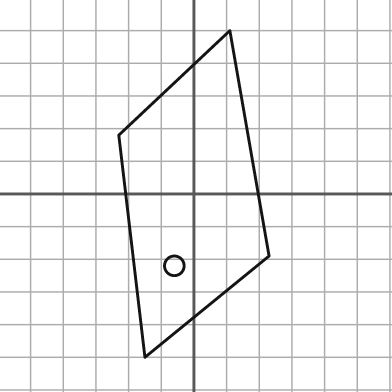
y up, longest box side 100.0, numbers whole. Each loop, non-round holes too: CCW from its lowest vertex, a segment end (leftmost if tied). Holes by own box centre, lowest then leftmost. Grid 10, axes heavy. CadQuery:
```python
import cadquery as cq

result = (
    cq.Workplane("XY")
    .moveTo(-15.0, -50.0)
    .lineTo(23.0, -19.0)
    .lineTo(11.0, 50.0)
    .lineTo(-23.0, 18.0)
    .close()
    .moveTo(-6.0, -22.0)
    .circle(3.0)
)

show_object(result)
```